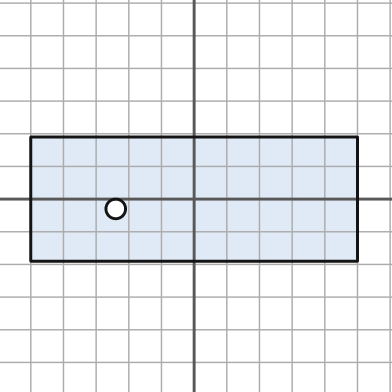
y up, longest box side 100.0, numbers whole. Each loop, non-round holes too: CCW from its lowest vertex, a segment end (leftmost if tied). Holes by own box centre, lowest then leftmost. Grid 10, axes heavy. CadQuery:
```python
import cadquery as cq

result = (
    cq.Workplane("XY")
    .moveTo(-50.0, -19.0)
    .lineTo(50.0, -19.0)
    .lineTo(50.0, 19.0)
    .lineTo(-50.0, 19.0)
    .close()
    .moveTo(-24.0, -3.0)
    .circle(3.0)
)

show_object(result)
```